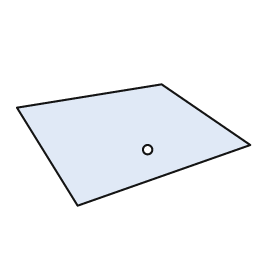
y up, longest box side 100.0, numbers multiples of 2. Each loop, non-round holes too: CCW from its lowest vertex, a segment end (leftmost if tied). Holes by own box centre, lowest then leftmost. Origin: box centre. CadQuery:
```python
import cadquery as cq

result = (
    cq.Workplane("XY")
    .moveTo(-24.0, -26.0)
    .lineTo(50.0, 0.0)
    .lineTo(12.0, 26.0)
    .lineTo(-50.0, 16.0)
    .close()
    .moveTo(6.0, -2.0)
    .circle(2.0)
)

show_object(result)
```